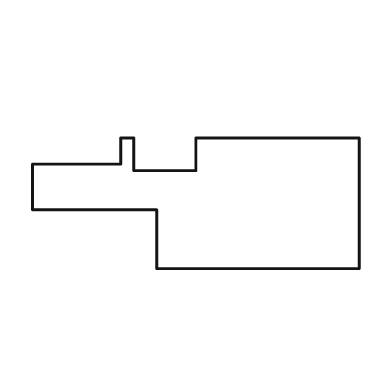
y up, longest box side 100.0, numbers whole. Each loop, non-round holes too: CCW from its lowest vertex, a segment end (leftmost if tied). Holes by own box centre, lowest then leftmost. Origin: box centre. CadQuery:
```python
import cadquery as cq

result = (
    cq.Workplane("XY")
    .moveTo(-12.0, -20.0)
    .lineTo(50.0, -20.0)
    .lineTo(50.0, 20.0)
    .lineTo(0.0, 20.0)
    .lineTo(0.0, 10.0)
    .lineTo(-19.0, 10.0)
    .lineTo(-19.0, 20.0)
    .lineTo(-23.0, 20.0)
    .lineTo(-23.0, 12.0)
    .lineTo(-50.0, 12.0)
    .lineTo(-50.0, -2.0)
    .lineTo(-12.0, -2.0)
    .close()
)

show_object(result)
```